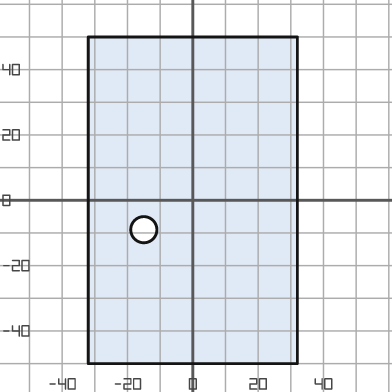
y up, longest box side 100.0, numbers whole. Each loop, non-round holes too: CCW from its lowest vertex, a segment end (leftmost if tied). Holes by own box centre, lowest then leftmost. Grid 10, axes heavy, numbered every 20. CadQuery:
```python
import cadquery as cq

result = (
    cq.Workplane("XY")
    .moveTo(-32.0, -50.0)
    .lineTo(32.0, -50.0)
    .lineTo(32.0, 50.0)
    .lineTo(-32.0, 50.0)
    .close()
    .moveTo(-15.0, -9.0)
    .circle(4.0)
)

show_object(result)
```